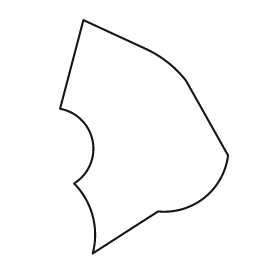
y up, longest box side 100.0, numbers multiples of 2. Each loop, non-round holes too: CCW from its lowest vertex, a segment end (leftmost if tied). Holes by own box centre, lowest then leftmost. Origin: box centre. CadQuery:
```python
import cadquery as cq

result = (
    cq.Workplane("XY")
    .moveTo(-22.0, -50.0)
    .lineTo(6.0, -32.0)
    .threePointArc((26.0, -26.0), (36.0, -8.0))
    .lineTo(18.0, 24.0)
    .threePointArc((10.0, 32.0), (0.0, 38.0))
    .lineTo(-26.0, 50.0)
    .lineTo(-36.0, 12.0)
    .threePointArc((-22.0, -2.0), (-30.0, -20.0))
    .threePointArc((-22.0, -34.0), (-22.0, -50.0))
    .close()
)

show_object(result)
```